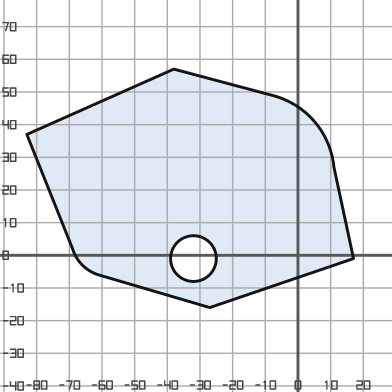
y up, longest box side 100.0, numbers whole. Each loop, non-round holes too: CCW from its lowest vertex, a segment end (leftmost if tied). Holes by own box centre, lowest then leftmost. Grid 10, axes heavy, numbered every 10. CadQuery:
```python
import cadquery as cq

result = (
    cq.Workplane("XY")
    .moveTo(-27.0, -16.0)
    .lineTo(17.0, -1.0)
    .lineTo(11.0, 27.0)
    .threePointArc((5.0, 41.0), (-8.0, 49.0))
    .lineTo(-38.0, 57.0)
    .lineTo(-83.0, 37.0)
    .lineTo(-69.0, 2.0)
    .threePointArc((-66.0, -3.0), (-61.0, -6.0))
    .close()
    .moveTo(-32.0, -1.0)
    .circle(7.0)
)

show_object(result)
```